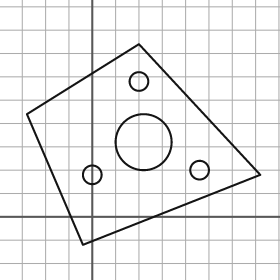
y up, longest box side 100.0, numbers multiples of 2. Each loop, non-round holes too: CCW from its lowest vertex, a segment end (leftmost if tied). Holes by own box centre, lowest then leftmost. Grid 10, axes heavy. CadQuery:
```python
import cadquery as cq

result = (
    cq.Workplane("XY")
    .moveTo(-4.0, -12.0)
    .lineTo(72.0, 18.0)
    .lineTo(20.0, 74.0)
    .lineTo(-28.0, 44.0)
    .close()
    .moveTo(0.0, 18.0)
    .circle(4.0)
    .moveTo(46.0, 20.0)
    .circle(4.0)
    .moveTo(22.0, 32.0)
    .circle(12.0)
    .moveTo(20.0, 58.0)
    .circle(4.0)
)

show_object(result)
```